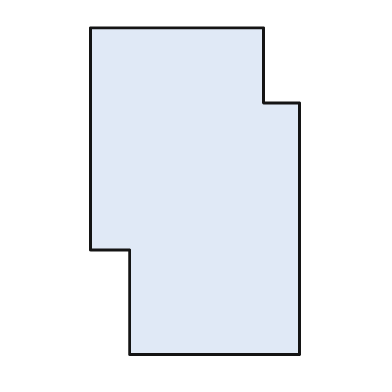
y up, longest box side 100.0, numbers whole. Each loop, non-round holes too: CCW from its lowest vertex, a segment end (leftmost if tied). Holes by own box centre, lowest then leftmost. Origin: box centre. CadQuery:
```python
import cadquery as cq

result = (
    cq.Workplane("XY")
    .moveTo(-20.0, -50.0)
    .lineTo(32.0, -50.0)
    .lineTo(32.0, 27.0)
    .lineTo(21.0, 27.0)
    .lineTo(21.0, 50.0)
    .lineTo(-32.0, 50.0)
    .lineTo(-32.0, -18.0)
    .lineTo(-20.0, -18.0)
    .close()
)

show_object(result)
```